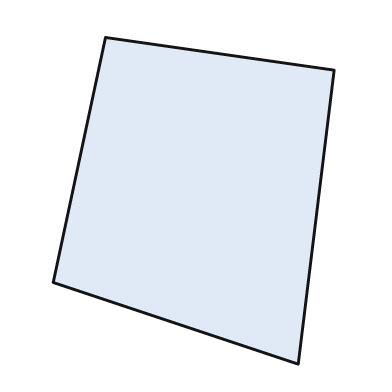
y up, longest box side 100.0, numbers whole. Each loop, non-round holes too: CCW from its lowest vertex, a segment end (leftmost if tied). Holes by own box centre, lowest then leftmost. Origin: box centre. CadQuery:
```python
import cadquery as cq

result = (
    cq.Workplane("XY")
    .moveTo(32.0, -50.0)
    .lineTo(43.0, 40.0)
    .lineTo(-27.0, 50.0)
    .lineTo(-43.0, -25.0)
    .close()
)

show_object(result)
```